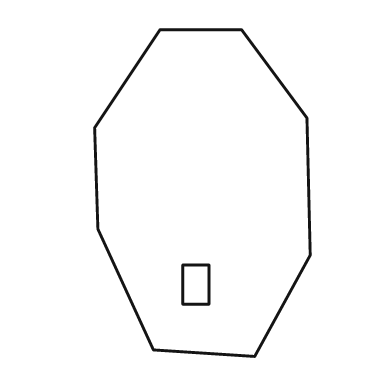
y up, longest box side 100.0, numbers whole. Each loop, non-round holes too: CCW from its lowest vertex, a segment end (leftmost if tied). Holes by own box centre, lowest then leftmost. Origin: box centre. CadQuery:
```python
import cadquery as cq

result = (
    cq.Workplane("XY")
    .moveTo(16.0, -50.0)
    .lineTo(33.0, -19.0)
    .lineTo(32.0, 23.0)
    .lineTo(12.0, 50.0)
    .lineTo(-13.0, 50.0)
    .lineTo(-33.0, 20.0)
    .lineTo(-32.0, -11.0)
    .lineTo(-15.0, -48.0)
    .close()
    .moveTo(-6.0, -34.0)
    .lineTo(2.0, -34.0)
    .lineTo(2.0, -22.0)
    .lineTo(-6.0, -22.0)
    .close()
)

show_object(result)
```